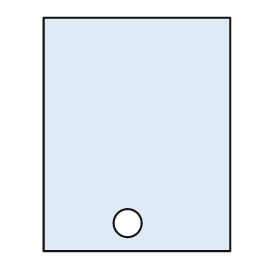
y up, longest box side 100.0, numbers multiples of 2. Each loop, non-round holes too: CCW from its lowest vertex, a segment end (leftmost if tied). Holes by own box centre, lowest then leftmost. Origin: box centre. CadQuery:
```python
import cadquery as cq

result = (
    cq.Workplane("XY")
    .moveTo(-40.0, -50.0)
    .lineTo(40.0, -50.0)
    .lineTo(40.0, 50.0)
    .lineTo(-40.0, 50.0)
    .close()
    .moveTo(-4.0, -38.0)
    .circle(6.0)
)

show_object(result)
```